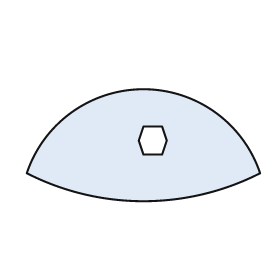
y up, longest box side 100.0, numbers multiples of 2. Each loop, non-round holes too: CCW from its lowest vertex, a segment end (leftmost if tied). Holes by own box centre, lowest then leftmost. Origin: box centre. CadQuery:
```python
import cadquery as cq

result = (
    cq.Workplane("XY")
    .moveTo(-50.0, -12.0)
    .threePointArc((0.0, -24.0), (50.0, -12.0))
    .threePointArc((0.0, 24.0), (-50.0, -12.0))
    .close()
    .moveTo(0.0, -4.0)
    .lineTo(8.0, -4.0)
    .lineTo(10.0, 2.0)
    .lineTo(8.0, 8.0)
    .lineTo(0.0, 8.0)
    .lineTo(-2.0, 2.0)
    .close()
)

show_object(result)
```